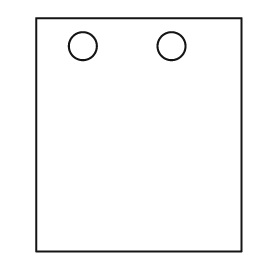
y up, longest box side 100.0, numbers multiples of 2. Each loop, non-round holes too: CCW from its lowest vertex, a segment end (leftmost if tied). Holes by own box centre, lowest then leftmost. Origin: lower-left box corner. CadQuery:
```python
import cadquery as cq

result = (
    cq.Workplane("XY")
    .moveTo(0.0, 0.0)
    .lineTo(88.0, 0.0)
    .lineTo(88.0, 100.0)
    .lineTo(0.0, 100.0)
    .close()
    .moveTo(20.0, 88.0)
    .circle(6.0)
    .moveTo(58.0, 88.0)
    .circle(6.0)
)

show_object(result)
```